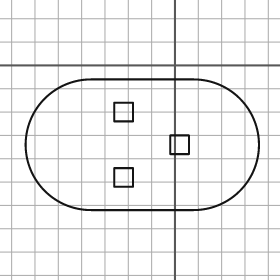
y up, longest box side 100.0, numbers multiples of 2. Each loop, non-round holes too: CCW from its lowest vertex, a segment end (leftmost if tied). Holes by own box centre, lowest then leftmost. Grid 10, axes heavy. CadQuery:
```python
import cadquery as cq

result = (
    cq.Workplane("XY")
    .moveTo(-36.0, -62.0)
    .lineTo(8.0, -62.0)
    .threePointArc((36.0, -34.0), (8.0, -6.0))
    .lineTo(-36.0, -6.0)
    .threePointArc((-64.0, -34.0), (-36.0, -62.0))
    .close()
    .moveTo(-26.0, -52.0)
    .lineTo(-18.0, -52.0)
    .lineTo(-18.0, -44.0)
    .lineTo(-26.0, -44.0)
    .close()
    .moveTo(-2.0, -38.0)
    .lineTo(6.0, -38.0)
    .lineTo(6.0, -30.0)
    .lineTo(-2.0, -30.0)
    .close()
    .moveTo(-26.0, -24.0)
    .lineTo(-18.0, -24.0)
    .lineTo(-18.0, -16.0)
    .lineTo(-26.0, -16.0)
    .close()
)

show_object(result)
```